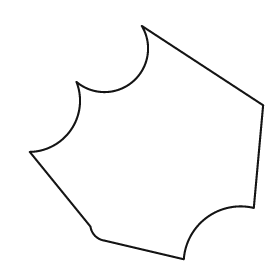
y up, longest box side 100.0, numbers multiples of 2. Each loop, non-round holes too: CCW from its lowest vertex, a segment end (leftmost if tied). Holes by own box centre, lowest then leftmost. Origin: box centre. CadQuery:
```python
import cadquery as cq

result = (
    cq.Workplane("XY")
    .moveTo(16.0, -50.0)
    .threePointArc((26.0, -32.0), (46.0, -28.0))
    .lineTo(50.0, 16.0)
    .lineTo(-2.0, 50.0)
    .threePointArc((-6.0, 26.0), (-30.0, 26.0))
    .threePointArc((-32.0, 6.0), (-50.0, -4.0))
    .lineTo(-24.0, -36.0)
    .threePointArc((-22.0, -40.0), (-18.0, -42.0))
    .close()
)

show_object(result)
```